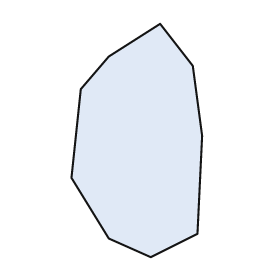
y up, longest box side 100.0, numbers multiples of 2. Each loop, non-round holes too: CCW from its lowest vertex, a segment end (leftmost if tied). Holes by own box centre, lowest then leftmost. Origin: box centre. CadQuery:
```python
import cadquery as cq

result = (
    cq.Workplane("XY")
    .moveTo(6.0, -50.0)
    .lineTo(26.0, -40.0)
    .lineTo(28.0, 2.0)
    .lineTo(24.0, 32.0)
    .lineTo(10.0, 50.0)
    .lineTo(-12.0, 36.0)
    .lineTo(-24.0, 22.0)
    .lineTo(-28.0, -16.0)
    .lineTo(-12.0, -42.0)
    .close()
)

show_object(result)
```